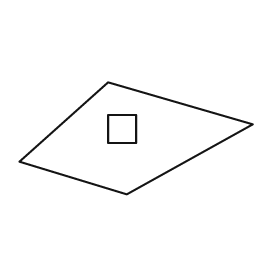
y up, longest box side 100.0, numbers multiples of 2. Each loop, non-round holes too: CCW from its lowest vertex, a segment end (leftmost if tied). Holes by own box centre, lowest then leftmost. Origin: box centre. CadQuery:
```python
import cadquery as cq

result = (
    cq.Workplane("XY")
    .moveTo(-4.0, -24.0)
    .lineTo(50.0, 6.0)
    .lineTo(-12.0, 24.0)
    .lineTo(-50.0, -10.0)
    .close()
    .moveTo(-12.0, -2.0)
    .lineTo(0.0, -2.0)
    .lineTo(0.0, 10.0)
    .lineTo(-12.0, 10.0)
    .close()
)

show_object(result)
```